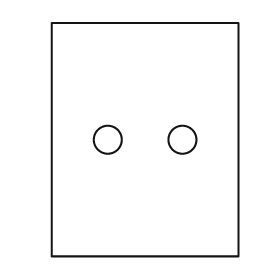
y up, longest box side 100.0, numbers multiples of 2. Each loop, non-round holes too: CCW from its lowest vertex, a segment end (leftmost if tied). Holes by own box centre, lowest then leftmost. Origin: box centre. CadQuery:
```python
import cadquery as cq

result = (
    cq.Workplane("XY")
    .moveTo(-40.0, -50.0)
    .lineTo(40.0, -50.0)
    .lineTo(40.0, 50.0)
    .lineTo(-40.0, 50.0)
    .close()
    .moveTo(-16.0, 0.0)
    .circle(6.0)
    .moveTo(16.0, 0.0)
    .circle(6.0)
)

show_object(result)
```